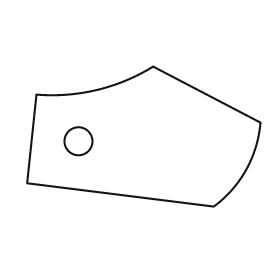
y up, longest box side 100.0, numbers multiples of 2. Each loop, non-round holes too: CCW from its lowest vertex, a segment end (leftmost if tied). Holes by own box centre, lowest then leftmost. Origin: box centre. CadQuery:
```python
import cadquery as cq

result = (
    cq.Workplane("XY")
    .moveTo(30.0, -30.0)
    .threePointArc((44.0, -14.0), (50.0, 6.0))
    .lineTo(4.0, 30.0)
    .threePointArc((-20.0, 20.0), (-46.0, 18.0))
    .lineTo(-50.0, -20.0)
    .close()
    .moveTo(-28.0, -2.0)
    .circle(6.0)
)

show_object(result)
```